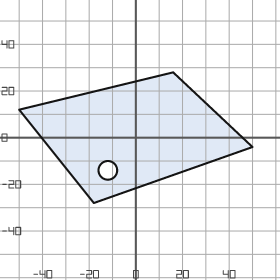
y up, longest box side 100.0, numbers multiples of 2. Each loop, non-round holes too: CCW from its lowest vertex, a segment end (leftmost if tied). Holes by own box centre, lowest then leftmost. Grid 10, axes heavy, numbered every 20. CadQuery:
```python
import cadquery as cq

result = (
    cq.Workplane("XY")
    .moveTo(-18.0, -28.0)
    .lineTo(50.0, -4.0)
    .lineTo(16.0, 28.0)
    .lineTo(-50.0, 12.0)
    .close()
    .moveTo(-12.0, -14.0)
    .circle(4.0)
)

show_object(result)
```